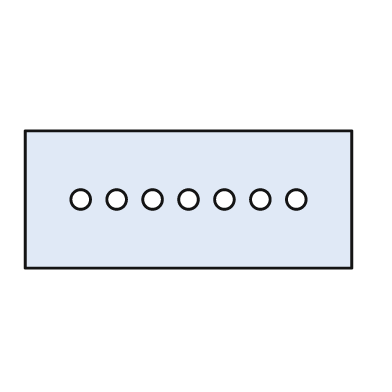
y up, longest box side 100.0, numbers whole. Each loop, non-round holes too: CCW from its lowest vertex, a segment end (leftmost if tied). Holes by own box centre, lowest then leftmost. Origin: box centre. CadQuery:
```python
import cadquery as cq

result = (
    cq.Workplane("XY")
    .moveTo(-50.0, -21.0)
    .lineTo(50.0, -21.0)
    .lineTo(50.0, 21.0)
    .lineTo(-50.0, 21.0)
    .close()
    .moveTo(-33.0, 0.0)
    .circle(3.0)
    .moveTo(-22.0, 0.0)
    .circle(3.0)
    .moveTo(-11.0, 0.0)
    .circle(3.0)
    .moveTo(0.0, 0.0)
    .circle(3.0)
    .moveTo(11.0, 0.0)
    .circle(3.0)
    .moveTo(22.0, 0.0)
    .circle(3.0)
    .moveTo(33.0, 0.0)
    .circle(3.0)
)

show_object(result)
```